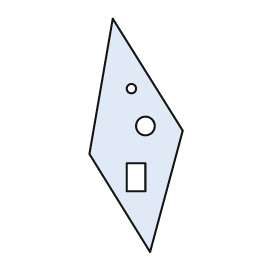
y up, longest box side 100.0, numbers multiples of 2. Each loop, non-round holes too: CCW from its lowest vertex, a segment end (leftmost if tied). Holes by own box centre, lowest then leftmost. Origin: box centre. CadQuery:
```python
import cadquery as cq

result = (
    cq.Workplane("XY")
    .moveTo(6.0, -50.0)
    .lineTo(20.0, 2.0)
    .lineTo(-10.0, 50.0)
    .lineTo(-20.0, -8.0)
    .close()
    .moveTo(-4.0, -24.0)
    .lineTo(4.0, -24.0)
    .lineTo(4.0, -12.0)
    .lineTo(-4.0, -12.0)
    .close()
    .moveTo(4.0, 4.0)
    .circle(4.0)
    .moveTo(-2.0, 20.0)
    .circle(2.0)
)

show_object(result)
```